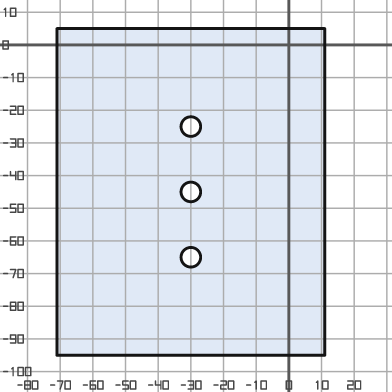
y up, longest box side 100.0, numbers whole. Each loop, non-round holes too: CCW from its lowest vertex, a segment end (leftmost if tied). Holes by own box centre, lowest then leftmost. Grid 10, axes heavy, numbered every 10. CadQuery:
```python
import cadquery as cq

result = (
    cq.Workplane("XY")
    .moveTo(-71.0, -95.0)
    .lineTo(11.0, -95.0)
    .lineTo(11.0, 5.0)
    .lineTo(-71.0, 5.0)
    .close()
    .moveTo(-30.0, -65.0)
    .circle(3.0)
    .moveTo(-30.0, -45.0)
    .circle(3.0)
    .moveTo(-30.0, -25.0)
    .circle(3.0)
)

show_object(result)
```